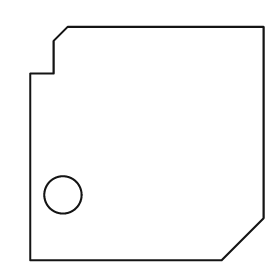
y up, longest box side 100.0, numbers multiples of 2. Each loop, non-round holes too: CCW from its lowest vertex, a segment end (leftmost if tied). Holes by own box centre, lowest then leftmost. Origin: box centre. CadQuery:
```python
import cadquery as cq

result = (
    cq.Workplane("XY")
    .moveTo(-50.0, -50.0)
    .lineTo(32.0, -50.0)
    .lineTo(50.0, -32.0)
    .lineTo(50.0, 50.0)
    .lineTo(-34.0, 50.0)
    .lineTo(-40.0, 44.0)
    .lineTo(-40.0, 30.0)
    .lineTo(-50.0, 30.0)
    .close()
    .moveTo(-36.0, -22.0)
    .circle(8.0)
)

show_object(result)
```